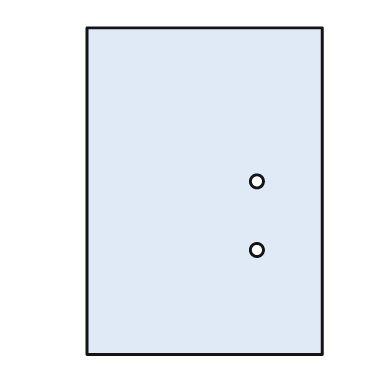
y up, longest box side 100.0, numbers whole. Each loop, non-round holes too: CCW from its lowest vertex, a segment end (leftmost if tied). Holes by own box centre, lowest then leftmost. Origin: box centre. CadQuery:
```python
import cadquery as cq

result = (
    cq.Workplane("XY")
    .moveTo(-36.0, -50.0)
    .lineTo(36.0, -50.0)
    .lineTo(36.0, 50.0)
    .lineTo(-36.0, 50.0)
    .close()
    .moveTo(16.0, -18.0)
    .circle(2.0)
    .moveTo(16.0, 3.0)
    .circle(2.0)
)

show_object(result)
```